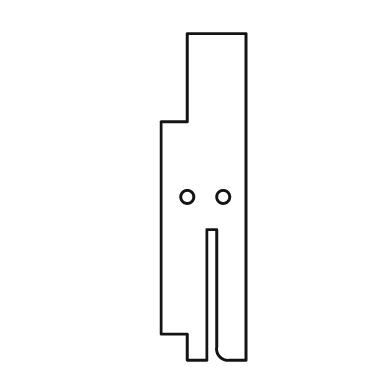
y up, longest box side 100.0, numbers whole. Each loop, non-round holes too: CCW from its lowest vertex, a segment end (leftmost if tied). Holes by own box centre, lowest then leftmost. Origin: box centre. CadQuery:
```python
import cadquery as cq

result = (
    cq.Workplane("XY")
    .moveTo(-5.0, -50.0)
    .lineTo(1.0, -50.0)
    .lineTo(1.0, -10.0)
    .lineTo(4.0, -10.0)
    .lineTo(4.0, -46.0)
    .threePointArc((5.0, -49.0), (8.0, -50.0))
    .lineTo(13.0, -50.0)
    .lineTo(13.0, 50.0)
    .lineTo(-5.0, 50.0)
    .lineTo(-5.0, 23.0)
    .lineTo(-13.0, 23.0)
    .lineTo(-13.0, -42.0)
    .lineTo(-5.0, -42.0)
    .close()
    .moveTo(-5.0, 0.0)
    .circle(2.0)
    .moveTo(6.0, 0.0)
    .circle(2.0)
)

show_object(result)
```